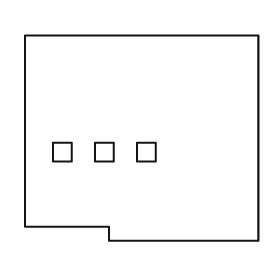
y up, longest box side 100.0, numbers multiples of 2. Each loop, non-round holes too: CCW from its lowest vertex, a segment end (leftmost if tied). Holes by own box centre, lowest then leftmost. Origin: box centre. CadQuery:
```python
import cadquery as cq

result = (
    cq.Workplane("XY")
    .moveTo(-14.0, -44.0)
    .lineTo(50.0, -44.0)
    .lineTo(50.0, 44.0)
    .lineTo(-50.0, 44.0)
    .lineTo(-50.0, -38.0)
    .lineTo(-14.0, -38.0)
    .close()
    .moveTo(-38.0, -10.0)
    .lineTo(-30.0, -10.0)
    .lineTo(-30.0, -2.0)
    .lineTo(-38.0, -2.0)
    .close()
    .moveTo(-20.0, -10.0)
    .lineTo(-12.0, -10.0)
    .lineTo(-12.0, -2.0)
    .lineTo(-20.0, -2.0)
    .close()
    .moveTo(-2.0, -10.0)
    .lineTo(6.0, -10.0)
    .lineTo(6.0, -2.0)
    .lineTo(-2.0, -2.0)
    .close()
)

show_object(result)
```